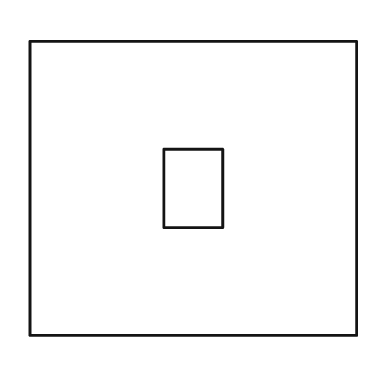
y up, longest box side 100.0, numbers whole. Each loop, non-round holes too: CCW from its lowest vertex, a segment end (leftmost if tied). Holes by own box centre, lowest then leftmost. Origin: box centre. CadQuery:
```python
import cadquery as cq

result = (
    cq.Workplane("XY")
    .moveTo(-50.0, -45.0)
    .lineTo(50.0, -45.0)
    .lineTo(50.0, 45.0)
    .lineTo(-50.0, 45.0)
    .close()
    .moveTo(-9.0, -12.0)
    .lineTo(9.0, -12.0)
    .lineTo(9.0, 12.0)
    .lineTo(-9.0, 12.0)
    .close()
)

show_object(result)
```